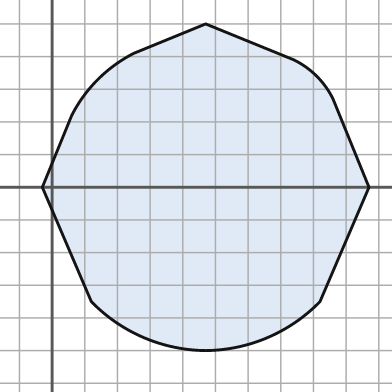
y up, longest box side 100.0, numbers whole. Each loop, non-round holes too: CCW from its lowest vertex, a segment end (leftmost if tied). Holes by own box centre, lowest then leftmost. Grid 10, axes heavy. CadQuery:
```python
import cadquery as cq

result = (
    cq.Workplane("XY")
    .moveTo(47.0, -50.0)
    .threePointArc((66.0, -46.0), (82.0, -35.0))
    .lineTo(97.0, 0.0)
    .lineTo(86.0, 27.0)
    .threePointArc((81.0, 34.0), (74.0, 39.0))
    .lineTo(47.0, 50.0)
    .lineTo(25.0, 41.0)
    .threePointArc((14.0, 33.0), (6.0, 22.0))
    .lineTo(-3.0, 0.0)
    .lineTo(12.0, -35.0)
    .threePointArc((28.0, -46.0), (47.0, -50.0))
    .close()
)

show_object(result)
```